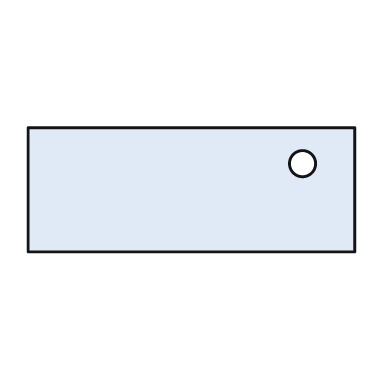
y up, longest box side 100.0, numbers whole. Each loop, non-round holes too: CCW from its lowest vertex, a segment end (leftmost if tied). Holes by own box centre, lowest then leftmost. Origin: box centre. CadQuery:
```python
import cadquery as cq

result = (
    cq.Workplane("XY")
    .moveTo(-50.0, -19.0)
    .lineTo(50.0, -19.0)
    .lineTo(50.0, 19.0)
    .lineTo(-50.0, 19.0)
    .close()
    .moveTo(34.0, 8.0)
    .circle(4.0)
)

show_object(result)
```